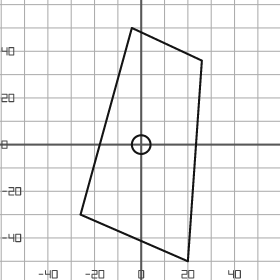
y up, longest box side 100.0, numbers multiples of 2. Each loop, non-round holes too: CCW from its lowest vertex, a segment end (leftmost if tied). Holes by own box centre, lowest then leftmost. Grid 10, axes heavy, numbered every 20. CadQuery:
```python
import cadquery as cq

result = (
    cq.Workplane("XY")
    .moveTo(20.0, -50.0)
    .lineTo(26.0, 36.0)
    .lineTo(-4.0, 50.0)
    .lineTo(-26.0, -30.0)
    .close()
    .moveTo(0.0, 0.0)
    .circle(4.0)
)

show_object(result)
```